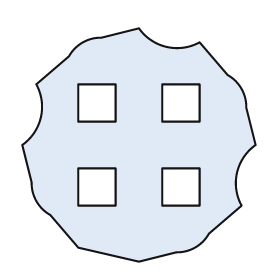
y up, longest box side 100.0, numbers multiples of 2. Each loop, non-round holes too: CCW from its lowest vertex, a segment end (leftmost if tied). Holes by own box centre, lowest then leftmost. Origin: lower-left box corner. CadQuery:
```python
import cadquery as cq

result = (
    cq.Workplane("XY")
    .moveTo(50.0, 0.0)
    .lineTo(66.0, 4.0)
    .threePointArc((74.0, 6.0), (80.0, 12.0))
    .lineTo(94.0, 24.0)
    .threePointArc((92.0, 38.0), (100.0, 50.0))
    .lineTo(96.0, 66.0)
    .threePointArc((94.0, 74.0), (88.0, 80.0))
    .lineTo(76.0, 94.0)
    .threePointArc((62.0, 92.0), (50.0, 100.0))
    .lineTo(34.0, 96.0)
    .threePointArc((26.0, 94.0), (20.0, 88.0))
    .lineTo(6.0, 76.0)
    .threePointArc((8.0, 62.0), (0.0, 50.0))
    .lineTo(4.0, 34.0)
    .threePointArc((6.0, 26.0), (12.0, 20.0))
    .lineTo(24.0, 6.0)
    .close()
    .moveTo(24.0, 24.0)
    .lineTo(40.0, 24.0)
    .lineTo(40.0, 40.0)
    .lineTo(24.0, 40.0)
    .close()
    .moveTo(60.0, 24.0)
    .lineTo(76.0, 24.0)
    .lineTo(76.0, 40.0)
    .lineTo(60.0, 40.0)
    .close()
    .moveTo(24.0, 60.0)
    .lineTo(40.0, 60.0)
    .lineTo(40.0, 76.0)
    .lineTo(24.0, 76.0)
    .close()
    .moveTo(60.0, 60.0)
    .lineTo(76.0, 60.0)
    .lineTo(76.0, 76.0)
    .lineTo(60.0, 76.0)
    .close()
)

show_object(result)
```